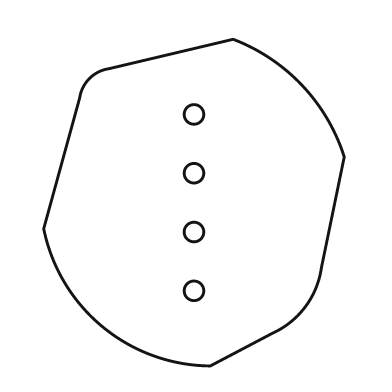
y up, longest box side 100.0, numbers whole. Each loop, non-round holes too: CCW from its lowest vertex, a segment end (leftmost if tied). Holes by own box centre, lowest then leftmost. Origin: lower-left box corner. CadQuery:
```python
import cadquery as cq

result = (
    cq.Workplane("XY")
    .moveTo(51.0, 0.0)
    .lineTo(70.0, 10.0)
    .threePointArc((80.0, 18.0), (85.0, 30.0))
    .lineTo(92.0, 64.0)
    .threePointArc((79.0, 86.0), (58.0, 100.0))
    .lineTo(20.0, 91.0)
    .threePointArc((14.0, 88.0), (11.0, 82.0))
    .lineTo(0.0, 42.0)
    .threePointArc((18.0, 12.0), (51.0, 0.0))
    .close()
    .moveTo(46.0, 23.0)
    .circle(3.0)
    .moveTo(46.0, 41.0)
    .circle(3.0)
    .moveTo(46.0, 59.0)
    .circle(3.0)
    .moveTo(46.0, 77.0)
    .circle(3.0)
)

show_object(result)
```